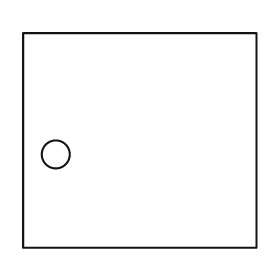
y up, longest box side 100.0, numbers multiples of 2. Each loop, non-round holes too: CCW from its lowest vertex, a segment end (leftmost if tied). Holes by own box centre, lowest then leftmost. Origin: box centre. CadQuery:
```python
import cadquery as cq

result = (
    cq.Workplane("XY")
    .moveTo(-50.0, -46.0)
    .lineTo(50.0, -46.0)
    .lineTo(50.0, 46.0)
    .lineTo(-50.0, 46.0)
    .close()
    .moveTo(-36.0, -6.0)
    .circle(6.0)
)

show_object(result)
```